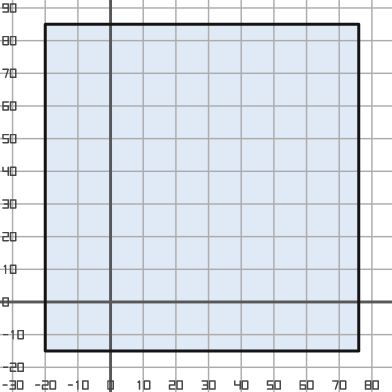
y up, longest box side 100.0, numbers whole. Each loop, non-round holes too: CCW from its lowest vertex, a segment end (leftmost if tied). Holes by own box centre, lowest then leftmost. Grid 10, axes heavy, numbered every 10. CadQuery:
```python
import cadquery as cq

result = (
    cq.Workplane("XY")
    .moveTo(-20.0, -15.0)
    .lineTo(76.0, -15.0)
    .lineTo(76.0, 85.0)
    .lineTo(-20.0, 85.0)
    .close()
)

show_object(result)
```